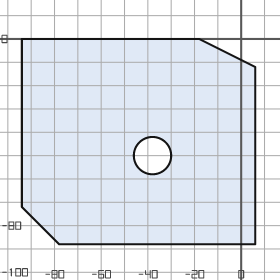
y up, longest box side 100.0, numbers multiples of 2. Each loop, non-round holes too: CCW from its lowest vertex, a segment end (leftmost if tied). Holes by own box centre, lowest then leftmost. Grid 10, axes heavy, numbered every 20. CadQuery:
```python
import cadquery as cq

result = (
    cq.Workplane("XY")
    .moveTo(-78.0, -88.0)
    .lineTo(6.0, -88.0)
    .lineTo(6.0, -12.0)
    .lineTo(-18.0, 0.0)
    .lineTo(-94.0, 0.0)
    .lineTo(-94.0, -72.0)
    .close()
    .moveTo(-38.0, -50.0)
    .circle(8.0)
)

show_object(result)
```